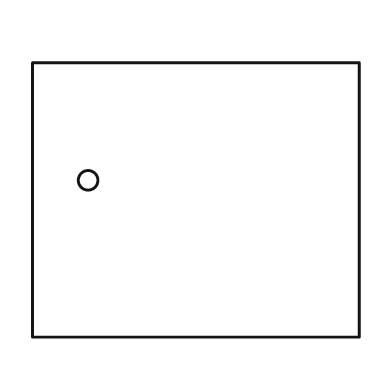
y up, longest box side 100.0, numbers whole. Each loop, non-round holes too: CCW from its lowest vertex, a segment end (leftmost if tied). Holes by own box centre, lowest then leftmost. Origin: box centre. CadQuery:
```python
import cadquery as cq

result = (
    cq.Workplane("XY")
    .moveTo(-50.0, -42.0)
    .lineTo(50.0, -42.0)
    .lineTo(50.0, 42.0)
    .lineTo(-50.0, 42.0)
    .close()
    .moveTo(-33.0, 6.0)
    .circle(3.0)
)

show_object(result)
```